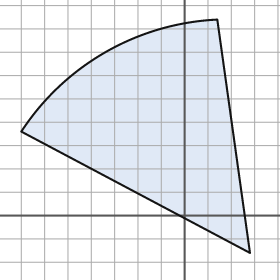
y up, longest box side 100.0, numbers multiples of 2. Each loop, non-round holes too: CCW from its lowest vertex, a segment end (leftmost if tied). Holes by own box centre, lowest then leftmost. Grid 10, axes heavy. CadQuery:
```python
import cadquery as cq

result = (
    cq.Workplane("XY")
    .moveTo(28.0, -16.0)
    .lineTo(14.0, 84.0)
    .threePointArc((-34.0, 70.0), (-70.0, 36.0))
    .close()
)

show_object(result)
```